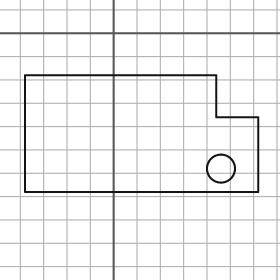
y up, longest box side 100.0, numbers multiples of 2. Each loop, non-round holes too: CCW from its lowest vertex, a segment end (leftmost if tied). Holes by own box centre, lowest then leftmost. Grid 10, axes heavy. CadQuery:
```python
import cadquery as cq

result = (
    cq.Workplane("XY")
    .moveTo(-38.0, -68.0)
    .lineTo(62.0, -68.0)
    .lineTo(62.0, -36.0)
    .lineTo(44.0, -36.0)
    .lineTo(44.0, -18.0)
    .lineTo(-38.0, -18.0)
    .close()
    .moveTo(46.0, -58.0)
    .circle(6.0)
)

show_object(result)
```